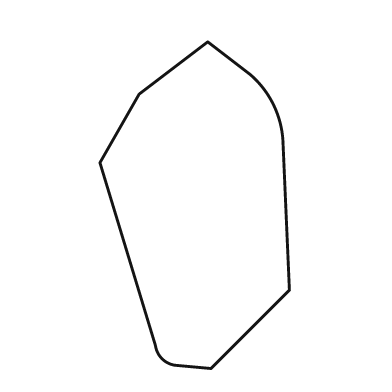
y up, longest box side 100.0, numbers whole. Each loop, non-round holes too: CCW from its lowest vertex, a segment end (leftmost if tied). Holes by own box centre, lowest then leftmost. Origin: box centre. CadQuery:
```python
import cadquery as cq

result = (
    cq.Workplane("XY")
    .moveTo(5.0, -50.0)
    .lineTo(29.0, -26.0)
    .lineTo(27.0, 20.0)
    .threePointArc((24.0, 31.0), (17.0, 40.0))
    .lineTo(4.0, 50.0)
    .lineTo(-17.0, 34.0)
    .lineTo(-29.0, 13.0)
    .lineTo(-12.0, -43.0)
    .threePointArc((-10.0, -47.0), (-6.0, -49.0))
    .close()
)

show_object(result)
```